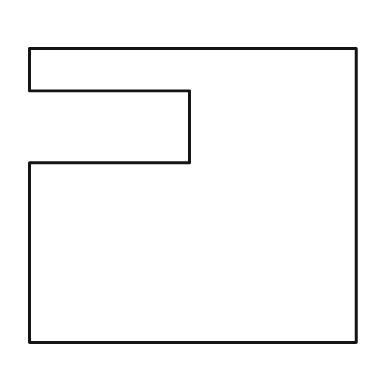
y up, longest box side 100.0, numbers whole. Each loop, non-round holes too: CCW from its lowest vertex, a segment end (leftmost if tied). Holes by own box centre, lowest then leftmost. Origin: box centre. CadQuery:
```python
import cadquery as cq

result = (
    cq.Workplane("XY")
    .moveTo(-50.0, -45.0)
    .lineTo(50.0, -45.0)
    .lineTo(50.0, 45.0)
    .lineTo(-50.0, 45.0)
    .lineTo(-50.0, 32.0)
    .lineTo(-1.0, 32.0)
    .lineTo(-1.0, 10.0)
    .lineTo(-50.0, 10.0)
    .close()
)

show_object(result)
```